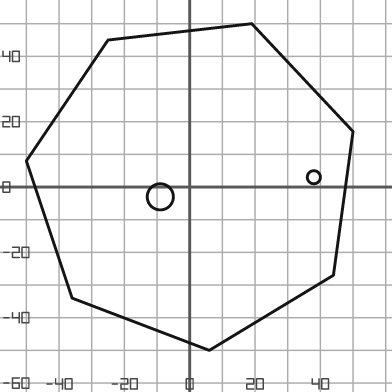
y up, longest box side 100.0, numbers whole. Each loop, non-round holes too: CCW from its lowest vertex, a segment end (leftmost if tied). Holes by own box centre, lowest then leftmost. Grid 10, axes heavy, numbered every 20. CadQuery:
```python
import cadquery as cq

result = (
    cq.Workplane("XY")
    .moveTo(6.0, -50.0)
    .lineTo(44.0, -27.0)
    .lineTo(50.0, 17.0)
    .lineTo(19.0, 50.0)
    .lineTo(-25.0, 45.0)
    .lineTo(-50.0, 8.0)
    .lineTo(-36.0, -34.0)
    .close()
    .moveTo(-9.0, -3.0)
    .circle(4.0)
    .moveTo(38.0, 3.0)
    .circle(2.0)
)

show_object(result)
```